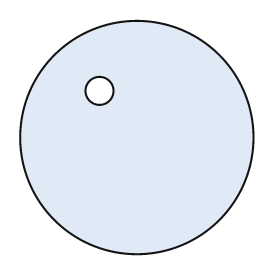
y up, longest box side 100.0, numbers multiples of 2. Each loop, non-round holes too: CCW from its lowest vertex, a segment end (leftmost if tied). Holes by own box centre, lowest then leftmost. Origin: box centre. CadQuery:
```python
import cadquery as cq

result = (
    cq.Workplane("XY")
    .moveTo(0.0, 0.0)
    .circle(50.0)
    .moveTo(-16.0, 20.0)
    .circle(6.0)
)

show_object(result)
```